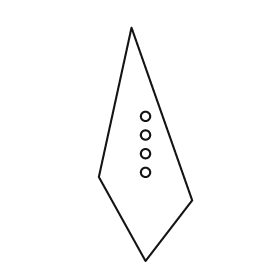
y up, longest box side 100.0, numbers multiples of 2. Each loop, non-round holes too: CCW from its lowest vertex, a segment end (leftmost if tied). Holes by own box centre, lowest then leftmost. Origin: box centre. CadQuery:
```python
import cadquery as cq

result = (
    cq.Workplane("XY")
    .moveTo(0.0, -50.0)
    .lineTo(20.0, -24.0)
    .lineTo(-6.0, 50.0)
    .lineTo(-20.0, -14.0)
    .close()
    .moveTo(0.0, -12.0)
    .circle(2.0)
    .moveTo(0.0, -4.0)
    .circle(2.0)
    .moveTo(0.0, 4.0)
    .circle(2.0)
    .moveTo(0.0, 12.0)
    .circle(2.0)
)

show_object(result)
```